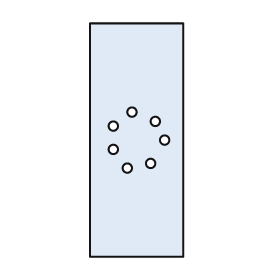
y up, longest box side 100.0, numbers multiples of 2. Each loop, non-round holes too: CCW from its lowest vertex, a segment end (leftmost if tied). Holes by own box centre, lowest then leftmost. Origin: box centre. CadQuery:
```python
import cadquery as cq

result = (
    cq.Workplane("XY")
    .moveTo(-20.0, -50.0)
    .lineTo(20.0, -50.0)
    .lineTo(20.0, 50.0)
    .lineTo(-20.0, 50.0)
    .close()
    .moveTo(-4.0, -12.0)
    .circle(2.0)
    .moveTo(6.0, -10.0)
    .circle(2.0)
    .moveTo(-10.0, -4.0)
    .circle(2.0)
    .moveTo(12.0, 0.0)
    .circle(2.0)
    .moveTo(-10.0, 6.0)
    .circle(2.0)
    .moveTo(8.0, 8.0)
    .circle(2.0)
    .moveTo(-2.0, 12.0)
    .circle(2.0)
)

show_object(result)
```